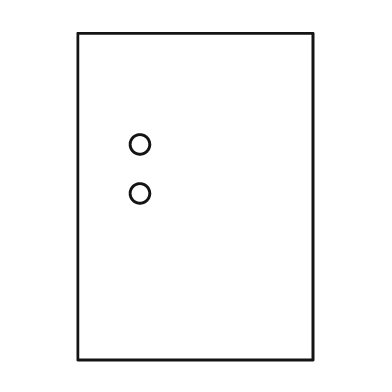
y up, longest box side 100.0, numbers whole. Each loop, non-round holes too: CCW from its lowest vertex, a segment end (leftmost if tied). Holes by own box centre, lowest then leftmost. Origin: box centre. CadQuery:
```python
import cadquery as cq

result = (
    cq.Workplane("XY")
    .moveTo(-36.0, -50.0)
    .lineTo(36.0, -50.0)
    .lineTo(36.0, 50.0)
    .lineTo(-36.0, 50.0)
    .close()
    .moveTo(-17.0, 1.0)
    .circle(3.0)
    .moveTo(-17.0, 16.0)
    .circle(3.0)
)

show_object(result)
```